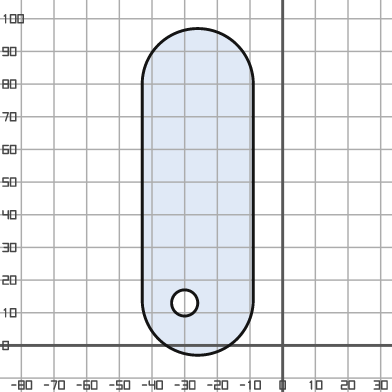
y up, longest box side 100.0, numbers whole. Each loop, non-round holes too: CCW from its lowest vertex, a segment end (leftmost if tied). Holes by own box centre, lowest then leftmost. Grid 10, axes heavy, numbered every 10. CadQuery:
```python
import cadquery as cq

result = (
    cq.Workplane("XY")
    .moveTo(-43.0, 14.0)
    .threePointArc((-26.0, -3.0), (-9.0, 14.0))
    .lineTo(-9.0, 80.0)
    .threePointArc((-26.0, 97.0), (-43.0, 80.0))
    .close()
    .moveTo(-30.0, 13.0)
    .circle(4.0)
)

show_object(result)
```